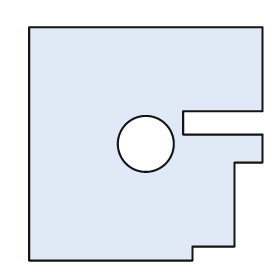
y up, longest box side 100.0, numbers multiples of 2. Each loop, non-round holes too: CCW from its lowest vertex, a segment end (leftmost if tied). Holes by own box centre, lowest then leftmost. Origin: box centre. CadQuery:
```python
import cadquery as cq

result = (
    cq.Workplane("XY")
    .moveTo(-50.0, -50.0)
    .lineTo(20.0, -50.0)
    .lineTo(20.0, -44.0)
    .lineTo(38.0, -44.0)
    .lineTo(38.0, -8.0)
    .lineTo(50.0, -8.0)
    .lineTo(50.0, 4.0)
    .lineTo(16.0, 4.0)
    .lineTo(16.0, 14.0)
    .lineTo(50.0, 14.0)
    .lineTo(50.0, 50.0)
    .lineTo(-50.0, 50.0)
    .close()
    .moveTo(0.0, 0.0)
    .circle(12.0)
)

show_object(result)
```